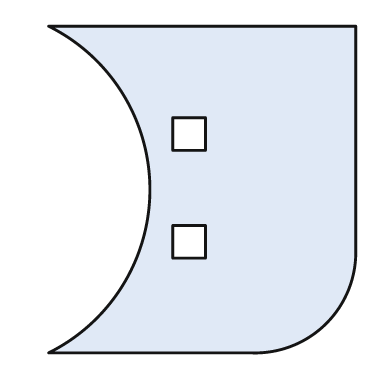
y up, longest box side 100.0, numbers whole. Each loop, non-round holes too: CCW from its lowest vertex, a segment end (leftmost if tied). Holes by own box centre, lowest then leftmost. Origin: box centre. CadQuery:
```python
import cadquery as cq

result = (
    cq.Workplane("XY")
    .moveTo(-47.0, -50.0)
    .lineTo(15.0, -50.0)
    .threePointArc((38.0, -41.0), (47.0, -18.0))
    .lineTo(47.0, 50.0)
    .lineTo(-47.0, 50.0)
    .threePointArc((-16.0, 0.0), (-47.0, -50.0))
    .close()
    .moveTo(-9.0, -21.0)
    .lineTo(1.0, -21.0)
    .lineTo(1.0, -11.0)
    .lineTo(-9.0, -11.0)
    .close()
    .moveTo(-9.0, 12.0)
    .lineTo(1.0, 12.0)
    .lineTo(1.0, 22.0)
    .lineTo(-9.0, 22.0)
    .close()
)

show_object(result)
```